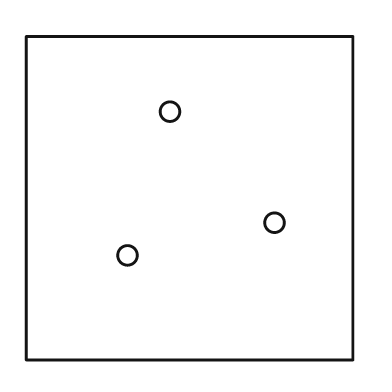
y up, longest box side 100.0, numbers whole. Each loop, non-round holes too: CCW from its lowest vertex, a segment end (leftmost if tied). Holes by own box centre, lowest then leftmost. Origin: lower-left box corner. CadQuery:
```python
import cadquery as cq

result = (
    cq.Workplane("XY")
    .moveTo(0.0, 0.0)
    .lineTo(100.0, 0.0)
    .lineTo(100.0, 99.0)
    .lineTo(0.0, 99.0)
    .close()
    .moveTo(31.0, 32.0)
    .circle(3.0)
    .moveTo(76.0, 42.0)
    .circle(3.0)
    .moveTo(44.0, 76.0)
    .circle(3.0)
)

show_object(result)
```